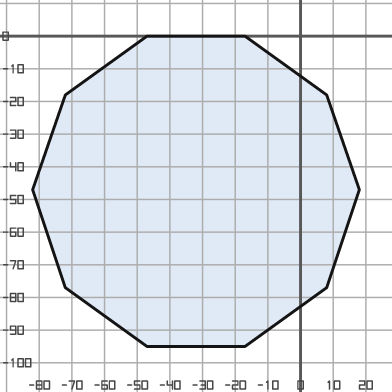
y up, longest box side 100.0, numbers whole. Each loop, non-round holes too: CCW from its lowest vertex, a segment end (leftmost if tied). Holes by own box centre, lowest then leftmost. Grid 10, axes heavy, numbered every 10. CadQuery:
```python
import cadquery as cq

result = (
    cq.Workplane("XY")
    .moveTo(-47.0, -95.0)
    .lineTo(-17.0, -95.0)
    .lineTo(8.0, -77.0)
    .lineTo(18.0, -47.0)
    .lineTo(8.0, -18.0)
    .lineTo(-17.0, 0.0)
    .lineTo(-47.0, 0.0)
    .lineTo(-72.0, -18.0)
    .lineTo(-82.0, -47.0)
    .lineTo(-72.0, -77.0)
    .close()
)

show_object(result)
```